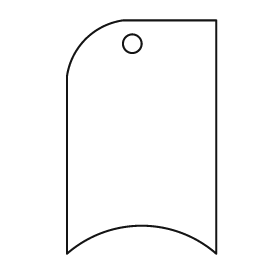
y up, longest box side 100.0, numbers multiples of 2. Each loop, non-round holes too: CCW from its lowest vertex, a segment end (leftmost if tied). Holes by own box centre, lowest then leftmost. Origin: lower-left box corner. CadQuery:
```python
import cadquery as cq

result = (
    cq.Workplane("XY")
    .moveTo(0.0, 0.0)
    .threePointArc((32.0, 12.0), (64.0, 0.0))
    .lineTo(64.0, 100.0)
    .lineTo(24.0, 100.0)
    .threePointArc((8.0, 92.0), (0.0, 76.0))
    .close()
    .moveTo(28.0, 90.0)
    .circle(4.0)
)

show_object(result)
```